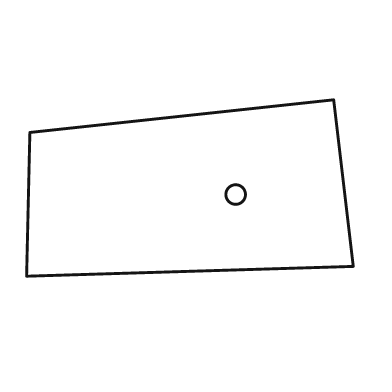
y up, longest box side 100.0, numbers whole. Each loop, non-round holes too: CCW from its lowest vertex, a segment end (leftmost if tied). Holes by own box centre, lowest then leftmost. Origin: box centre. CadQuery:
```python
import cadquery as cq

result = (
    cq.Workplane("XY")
    .moveTo(-50.0, -27.0)
    .lineTo(50.0, -24.0)
    .lineTo(44.0, 27.0)
    .lineTo(-49.0, 17.0)
    .close()
    .moveTo(14.0, -2.0)
    .circle(3.0)
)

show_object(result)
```